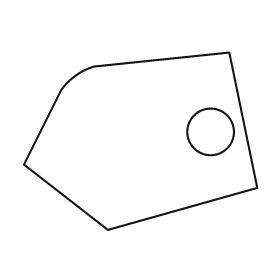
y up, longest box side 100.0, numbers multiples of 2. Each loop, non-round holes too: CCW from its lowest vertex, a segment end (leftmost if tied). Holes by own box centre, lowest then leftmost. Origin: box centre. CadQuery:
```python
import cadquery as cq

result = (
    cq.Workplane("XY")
    .moveTo(-14.0, -38.0)
    .lineTo(50.0, -20.0)
    .lineTo(38.0, 38.0)
    .lineTo(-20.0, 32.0)
    .threePointArc((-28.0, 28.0), (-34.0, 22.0))
    .lineTo(-50.0, -10.0)
    .close()
    .moveTo(30.0, 4.0)
    .circle(10.0)
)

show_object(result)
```